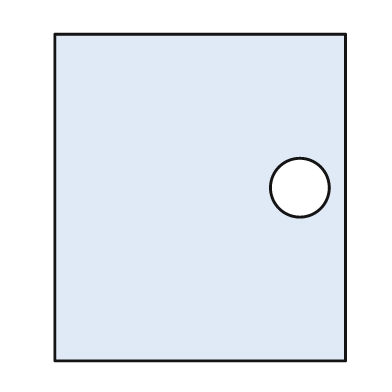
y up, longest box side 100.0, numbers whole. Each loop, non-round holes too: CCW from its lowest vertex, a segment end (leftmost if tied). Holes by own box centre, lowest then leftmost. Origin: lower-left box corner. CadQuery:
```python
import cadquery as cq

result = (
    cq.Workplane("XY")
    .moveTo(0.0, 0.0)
    .lineTo(89.0, 0.0)
    .lineTo(89.0, 100.0)
    .lineTo(0.0, 100.0)
    .close()
    .moveTo(75.0, 53.0)
    .circle(9.0)
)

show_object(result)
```